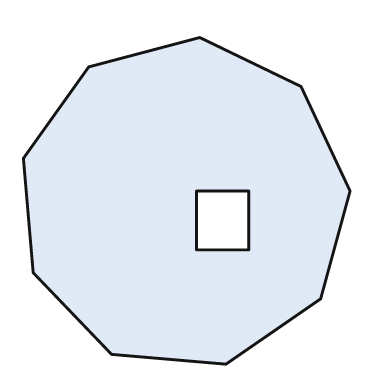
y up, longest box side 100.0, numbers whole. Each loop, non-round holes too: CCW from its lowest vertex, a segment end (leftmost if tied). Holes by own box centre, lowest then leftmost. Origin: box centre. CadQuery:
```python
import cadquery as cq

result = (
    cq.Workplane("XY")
    .moveTo(12.0, -50.0)
    .lineTo(41.0, -30.0)
    .lineTo(50.0, 3.0)
    .lineTo(35.0, 35.0)
    .lineTo(4.0, 50.0)
    .lineTo(-30.0, 41.0)
    .lineTo(-50.0, 13.0)
    .lineTo(-47.0, -22.0)
    .lineTo(-23.0, -47.0)
    .close()
    .moveTo(3.0, -15.0)
    .lineTo(19.0, -15.0)
    .lineTo(19.0, 3.0)
    .lineTo(3.0, 3.0)
    .close()
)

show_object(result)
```